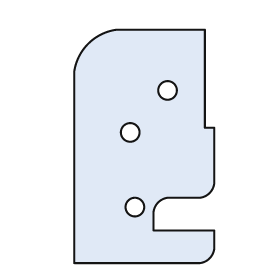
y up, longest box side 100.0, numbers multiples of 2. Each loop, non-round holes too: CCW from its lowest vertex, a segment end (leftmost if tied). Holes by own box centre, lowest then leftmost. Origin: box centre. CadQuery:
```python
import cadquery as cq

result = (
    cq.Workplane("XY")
    .moveTo(-30.0, -50.0)
    .lineTo(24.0, -50.0)
    .threePointArc((28.0, -48.0), (30.0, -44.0))
    .lineTo(30.0, -36.0)
    .lineTo(4.0, -36.0)
    .lineTo(4.0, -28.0)
    .threePointArc((6.0, -24.0), (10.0, -22.0))
    .lineTo(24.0, -22.0)
    .threePointArc((28.0, -20.0), (30.0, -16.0))
    .lineTo(30.0, 8.0)
    .lineTo(26.0, 8.0)
    .lineTo(26.0, 50.0)
    .lineTo(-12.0, 50.0)
    .threePointArc((-24.0, 44.0), (-30.0, 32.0))
    .close()
    .moveTo(-4.0, -26.0)
    .circle(4.0)
    .moveTo(-6.0, 6.0)
    .circle(4.0)
    .moveTo(10.0, 24.0)
    .circle(4.0)
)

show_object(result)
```